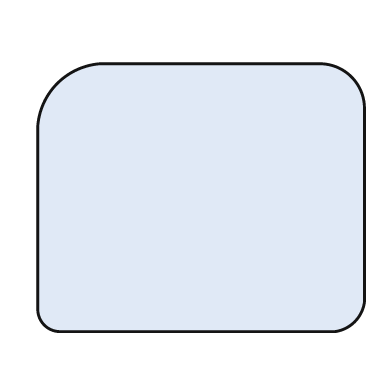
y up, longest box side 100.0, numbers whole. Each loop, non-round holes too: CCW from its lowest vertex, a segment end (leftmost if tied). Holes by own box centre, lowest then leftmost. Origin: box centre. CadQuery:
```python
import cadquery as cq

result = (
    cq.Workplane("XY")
    .moveTo(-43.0, -41.0)
    .lineTo(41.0, -41.0)
    .threePointArc((47.0, -38.0), (50.0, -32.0))
    .lineTo(50.0, 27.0)
    .threePointArc((46.0, 37.0), (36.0, 41.0))
    .lineTo(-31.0, 41.0)
    .threePointArc((-44.0, 35.0), (-50.0, 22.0))
    .lineTo(-50.0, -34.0)
    .threePointArc((-48.0, -39.0), (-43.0, -41.0))
    .close()
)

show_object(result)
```